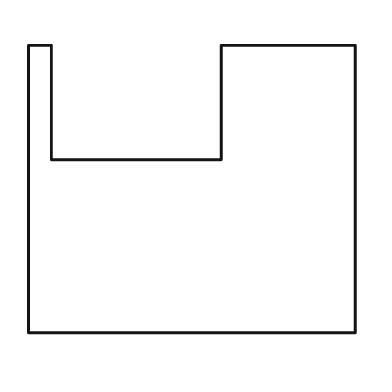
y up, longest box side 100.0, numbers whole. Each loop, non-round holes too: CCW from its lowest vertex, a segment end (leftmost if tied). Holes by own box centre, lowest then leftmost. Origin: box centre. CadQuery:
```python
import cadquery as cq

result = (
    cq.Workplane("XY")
    .moveTo(-50.0, -44.0)
    .lineTo(50.0, -44.0)
    .lineTo(50.0, 44.0)
    .lineTo(9.0, 44.0)
    .lineTo(9.0, 9.0)
    .lineTo(-43.0, 9.0)
    .lineTo(-43.0, 44.0)
    .lineTo(-50.0, 44.0)
    .close()
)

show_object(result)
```